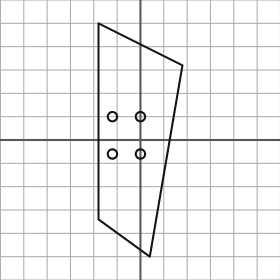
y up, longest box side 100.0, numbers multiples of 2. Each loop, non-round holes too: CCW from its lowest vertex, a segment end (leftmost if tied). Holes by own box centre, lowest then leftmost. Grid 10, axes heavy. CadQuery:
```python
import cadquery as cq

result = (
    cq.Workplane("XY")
    .moveTo(4.0, -50.0)
    .lineTo(18.0, 32.0)
    .lineTo(-18.0, 50.0)
    .lineTo(-18.0, -34.0)
    .close()
    .moveTo(-12.0, -6.0)
    .circle(2.0)
    .moveTo(0.0, -6.0)
    .circle(2.0)
    .moveTo(-12.0, 10.0)
    .circle(2.0)
    .moveTo(0.0, 10.0)
    .circle(2.0)
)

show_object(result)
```